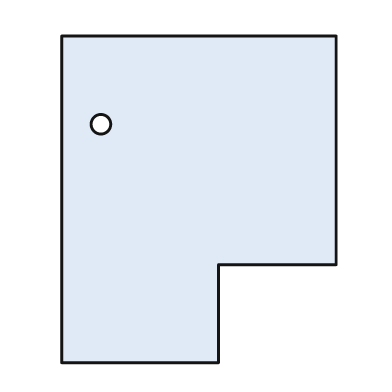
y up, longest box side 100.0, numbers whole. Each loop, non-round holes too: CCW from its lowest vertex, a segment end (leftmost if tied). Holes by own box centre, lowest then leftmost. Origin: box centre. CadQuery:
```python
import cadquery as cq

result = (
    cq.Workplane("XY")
    .moveTo(-42.0, -50.0)
    .lineTo(6.0, -50.0)
    .lineTo(6.0, -20.0)
    .lineTo(42.0, -20.0)
    .lineTo(42.0, 50.0)
    .lineTo(-42.0, 50.0)
    .close()
    .moveTo(-30.0, 23.0)
    .circle(3.0)
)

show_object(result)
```